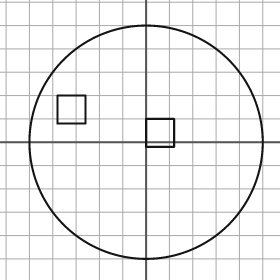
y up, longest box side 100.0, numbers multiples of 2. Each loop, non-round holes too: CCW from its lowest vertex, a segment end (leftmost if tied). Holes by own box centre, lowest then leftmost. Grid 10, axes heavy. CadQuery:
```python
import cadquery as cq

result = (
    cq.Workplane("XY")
    .moveTo(0.0, 0.0)
    .circle(50.0)
    .moveTo(0.0, -2.0)
    .lineTo(12.0, -2.0)
    .lineTo(12.0, 10.0)
    .lineTo(0.0, 10.0)
    .close()
    .moveTo(-38.0, 8.0)
    .lineTo(-26.0, 8.0)
    .lineTo(-26.0, 20.0)
    .lineTo(-38.0, 20.0)
    .close()
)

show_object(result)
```